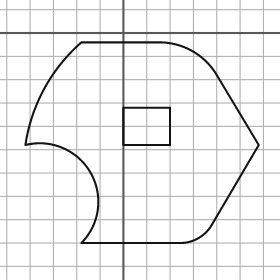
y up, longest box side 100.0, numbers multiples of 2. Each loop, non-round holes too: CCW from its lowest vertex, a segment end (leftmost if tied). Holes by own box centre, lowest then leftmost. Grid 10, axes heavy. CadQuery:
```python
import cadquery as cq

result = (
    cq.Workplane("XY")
    .moveTo(-18.0, -90.0)
    .lineTo(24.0, -90.0)
    .threePointArc((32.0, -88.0), (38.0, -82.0))
    .lineTo(58.0, -48.0)
    .lineTo(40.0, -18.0)
    .threePointArc((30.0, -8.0), (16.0, -4.0))
    .lineTo(-18.0, -4.0)
    .threePointArc((-34.0, -24.0), (-42.0, -48.0))
    .threePointArc((-14.0, -60.0), (-18.0, -90.0))
    .close()
    .moveTo(0.0, -48.0)
    .lineTo(20.0, -48.0)
    .lineTo(20.0, -32.0)
    .lineTo(0.0, -32.0)
    .close()
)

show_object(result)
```